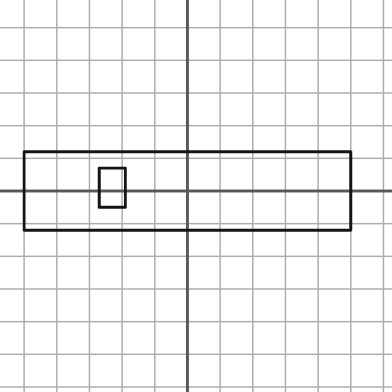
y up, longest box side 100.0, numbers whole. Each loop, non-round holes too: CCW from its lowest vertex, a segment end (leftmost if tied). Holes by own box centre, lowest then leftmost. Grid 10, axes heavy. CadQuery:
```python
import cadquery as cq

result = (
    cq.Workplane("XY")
    .moveTo(-50.0, -12.0)
    .lineTo(50.0, -12.0)
    .lineTo(50.0, 12.0)
    .lineTo(-50.0, 12.0)
    .close()
    .moveTo(-27.0, -5.0)
    .lineTo(-19.0, -5.0)
    .lineTo(-19.0, 7.0)
    .lineTo(-27.0, 7.0)
    .close()
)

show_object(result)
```